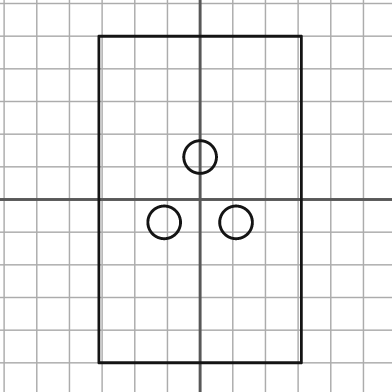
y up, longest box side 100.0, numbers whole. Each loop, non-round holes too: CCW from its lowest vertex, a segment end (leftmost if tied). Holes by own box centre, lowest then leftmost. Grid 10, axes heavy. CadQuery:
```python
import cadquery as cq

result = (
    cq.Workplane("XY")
    .moveTo(-31.0, -50.0)
    .lineTo(31.0, -50.0)
    .lineTo(31.0, 50.0)
    .lineTo(-31.0, 50.0)
    .close()
    .moveTo(-11.0, -7.0)
    .circle(5.0)
    .moveTo(11.0, -7.0)
    .circle(5.0)
    .moveTo(0.0, 13.0)
    .circle(5.0)
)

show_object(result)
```